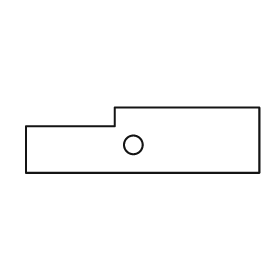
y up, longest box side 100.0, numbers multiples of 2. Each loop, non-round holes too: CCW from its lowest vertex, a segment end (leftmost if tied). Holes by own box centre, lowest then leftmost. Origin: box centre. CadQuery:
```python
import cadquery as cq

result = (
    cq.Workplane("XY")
    .moveTo(-50.0, -14.0)
    .lineTo(50.0, -14.0)
    .lineTo(50.0, 14.0)
    .lineTo(-12.0, 14.0)
    .lineTo(-12.0, 6.0)
    .lineTo(-50.0, 6.0)
    .close()
    .moveTo(-4.0, -2.0)
    .circle(4.0)
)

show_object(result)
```